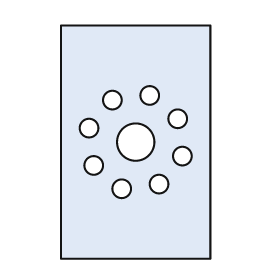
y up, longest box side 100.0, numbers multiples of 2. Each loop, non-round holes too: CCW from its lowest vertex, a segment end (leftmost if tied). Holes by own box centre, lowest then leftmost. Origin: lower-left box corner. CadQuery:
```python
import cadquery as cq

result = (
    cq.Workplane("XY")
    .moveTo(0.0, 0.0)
    .lineTo(64.0, 0.0)
    .lineTo(64.0, 100.0)
    .lineTo(0.0, 100.0)
    .close()
    .moveTo(26.0, 30.0)
    .circle(4.0)
    .moveTo(42.0, 32.0)
    .circle(4.0)
    .moveTo(14.0, 40.0)
    .circle(4.0)
    .moveTo(52.0, 44.0)
    .circle(4.0)
    .moveTo(32.0, 50.0)
    .circle(8.0)
    .moveTo(12.0, 56.0)
    .circle(4.0)
    .moveTo(50.0, 60.0)
    .circle(4.0)
    .moveTo(22.0, 68.0)
    .circle(4.0)
    .moveTo(38.0, 70.0)
    .circle(4.0)
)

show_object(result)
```